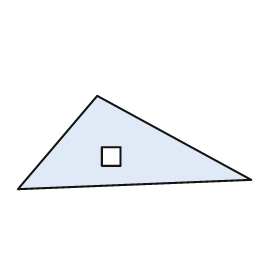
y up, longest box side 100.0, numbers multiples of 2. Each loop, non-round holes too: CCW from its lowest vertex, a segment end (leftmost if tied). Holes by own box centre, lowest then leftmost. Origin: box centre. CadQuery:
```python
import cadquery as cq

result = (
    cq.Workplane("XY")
    .moveTo(-50.0, -20.0)
    .lineTo(50.0, -16.0)
    .lineTo(-16.0, 20.0)
    .close()
    .moveTo(-14.0, -10.0)
    .lineTo(-6.0, -10.0)
    .lineTo(-6.0, -2.0)
    .lineTo(-14.0, -2.0)
    .close()
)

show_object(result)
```